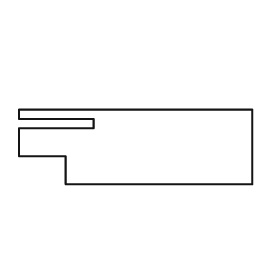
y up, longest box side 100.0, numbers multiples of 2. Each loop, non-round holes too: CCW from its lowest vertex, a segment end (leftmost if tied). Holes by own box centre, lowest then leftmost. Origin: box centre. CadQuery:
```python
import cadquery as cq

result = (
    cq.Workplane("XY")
    .moveTo(-30.0, -16.0)
    .lineTo(50.0, -16.0)
    .lineTo(50.0, 16.0)
    .lineTo(-50.0, 16.0)
    .lineTo(-50.0, 12.0)
    .lineTo(-18.0, 12.0)
    .lineTo(-18.0, 8.0)
    .lineTo(-50.0, 8.0)
    .lineTo(-50.0, -4.0)
    .lineTo(-30.0, -4.0)
    .close()
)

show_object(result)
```